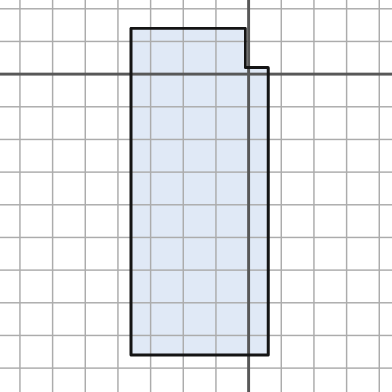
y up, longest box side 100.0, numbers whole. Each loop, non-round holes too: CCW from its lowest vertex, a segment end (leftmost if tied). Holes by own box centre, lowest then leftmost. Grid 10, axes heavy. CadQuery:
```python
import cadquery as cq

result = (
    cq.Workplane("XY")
    .moveTo(-36.0, -86.0)
    .lineTo(6.0, -86.0)
    .lineTo(6.0, 2.0)
    .lineTo(-1.0, 2.0)
    .lineTo(-1.0, 14.0)
    .lineTo(-36.0, 14.0)
    .close()
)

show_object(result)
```